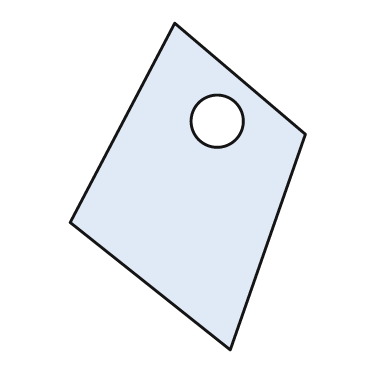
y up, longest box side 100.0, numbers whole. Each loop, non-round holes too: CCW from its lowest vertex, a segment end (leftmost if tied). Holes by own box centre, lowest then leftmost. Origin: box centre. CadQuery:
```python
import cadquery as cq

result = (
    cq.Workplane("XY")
    .moveTo(13.0, -50.0)
    .lineTo(36.0, 16.0)
    .lineTo(-4.0, 50.0)
    .lineTo(-36.0, -11.0)
    .close()
    .moveTo(9.0, 20.0)
    .circle(8.0)
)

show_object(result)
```